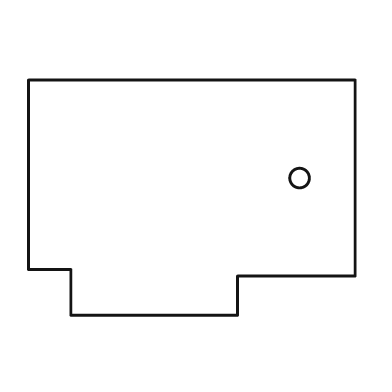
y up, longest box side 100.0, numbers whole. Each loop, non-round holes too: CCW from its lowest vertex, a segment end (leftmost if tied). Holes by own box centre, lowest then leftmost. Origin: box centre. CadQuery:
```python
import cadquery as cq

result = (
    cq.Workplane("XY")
    .moveTo(-37.0, -36.0)
    .lineTo(14.0, -36.0)
    .lineTo(14.0, -24.0)
    .lineTo(50.0, -24.0)
    .lineTo(50.0, 36.0)
    .lineTo(-50.0, 36.0)
    .lineTo(-50.0, -22.0)
    .lineTo(-37.0, -22.0)
    .close()
    .moveTo(33.0, 6.0)
    .circle(3.0)
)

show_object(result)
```